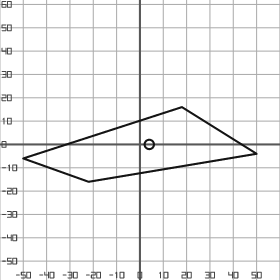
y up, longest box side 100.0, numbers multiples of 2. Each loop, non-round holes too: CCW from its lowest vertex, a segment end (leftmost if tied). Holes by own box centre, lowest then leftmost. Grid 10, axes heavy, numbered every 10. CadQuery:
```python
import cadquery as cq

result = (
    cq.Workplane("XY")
    .moveTo(-22.0, -16.0)
    .lineTo(50.0, -4.0)
    .lineTo(18.0, 16.0)
    .lineTo(-50.0, -6.0)
    .close()
    .moveTo(4.0, 0.0)
    .circle(2.0)
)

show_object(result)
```